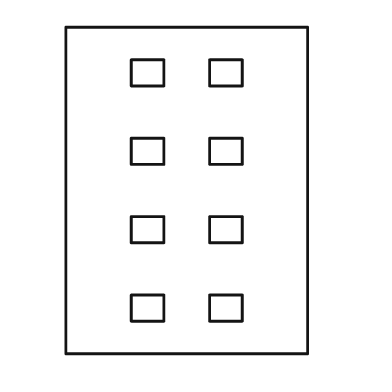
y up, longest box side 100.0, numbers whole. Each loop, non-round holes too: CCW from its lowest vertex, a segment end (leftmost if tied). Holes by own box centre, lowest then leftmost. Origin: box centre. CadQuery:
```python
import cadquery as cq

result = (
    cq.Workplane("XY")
    .moveTo(-37.0, -50.0)
    .lineTo(37.0, -50.0)
    .lineTo(37.0, 50.0)
    .lineTo(-37.0, 50.0)
    .close()
    .moveTo(-17.0, -40.0)
    .lineTo(-7.0, -40.0)
    .lineTo(-7.0, -32.0)
    .lineTo(-17.0, -32.0)
    .close()
    .moveTo(7.0, -40.0)
    .lineTo(17.0, -40.0)
    .lineTo(17.0, -32.0)
    .lineTo(7.0, -32.0)
    .close()
    .moveTo(-17.0, -16.0)
    .lineTo(-7.0, -16.0)
    .lineTo(-7.0, -8.0)
    .lineTo(-17.0, -8.0)
    .close()
    .moveTo(7.0, -16.0)
    .lineTo(17.0, -16.0)
    .lineTo(17.0, -8.0)
    .lineTo(7.0, -8.0)
    .close()
    .moveTo(-17.0, 8.0)
    .lineTo(-7.0, 8.0)
    .lineTo(-7.0, 16.0)
    .lineTo(-17.0, 16.0)
    .close()
    .moveTo(7.0, 8.0)
    .lineTo(17.0, 8.0)
    .lineTo(17.0, 16.0)
    .lineTo(7.0, 16.0)
    .close()
    .moveTo(-17.0, 32.0)
    .lineTo(-7.0, 32.0)
    .lineTo(-7.0, 40.0)
    .lineTo(-17.0, 40.0)
    .close()
    .moveTo(7.0, 32.0)
    .lineTo(17.0, 32.0)
    .lineTo(17.0, 40.0)
    .lineTo(7.0, 40.0)
    .close()
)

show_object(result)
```